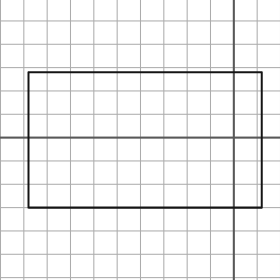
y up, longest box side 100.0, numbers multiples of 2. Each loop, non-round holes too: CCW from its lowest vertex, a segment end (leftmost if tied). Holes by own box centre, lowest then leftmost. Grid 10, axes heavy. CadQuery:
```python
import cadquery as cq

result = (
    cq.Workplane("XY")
    .moveTo(-88.0, -30.0)
    .lineTo(12.0, -30.0)
    .lineTo(12.0, 28.0)
    .lineTo(-88.0, 28.0)
    .close()
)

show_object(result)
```